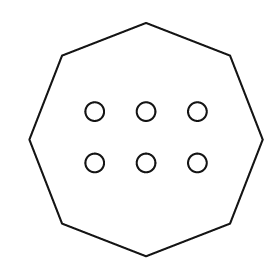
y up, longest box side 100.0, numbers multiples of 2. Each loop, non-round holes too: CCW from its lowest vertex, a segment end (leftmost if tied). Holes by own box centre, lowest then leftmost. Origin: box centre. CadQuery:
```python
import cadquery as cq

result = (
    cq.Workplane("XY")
    .moveTo(0.0, -50.0)
    .lineTo(36.0, -36.0)
    .lineTo(50.0, 0.0)
    .lineTo(36.0, 36.0)
    .lineTo(0.0, 50.0)
    .lineTo(-36.0, 36.0)
    .lineTo(-50.0, 0.0)
    .lineTo(-36.0, -36.0)
    .close()
    .moveTo(-22.0, -10.0)
    .circle(4.0)
    .moveTo(0.0, -10.0)
    .circle(4.0)
    .moveTo(22.0, -10.0)
    .circle(4.0)
    .moveTo(-22.0, 12.0)
    .circle(4.0)
    .moveTo(0.0, 12.0)
    .circle(4.0)
    .moveTo(22.0, 12.0)
    .circle(4.0)
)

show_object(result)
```